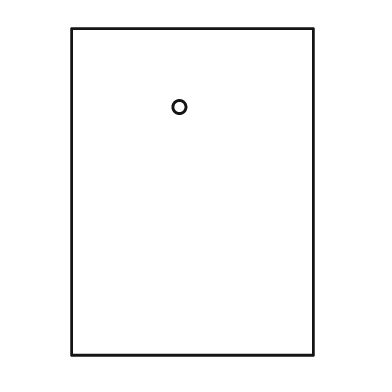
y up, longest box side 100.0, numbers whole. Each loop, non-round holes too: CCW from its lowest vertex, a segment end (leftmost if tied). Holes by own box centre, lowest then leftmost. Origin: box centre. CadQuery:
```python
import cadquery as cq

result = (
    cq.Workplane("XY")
    .moveTo(-37.0, -50.0)
    .lineTo(37.0, -50.0)
    .lineTo(37.0, 50.0)
    .lineTo(-37.0, 50.0)
    .close()
    .moveTo(-4.0, 26.0)
    .circle(2.0)
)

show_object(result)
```